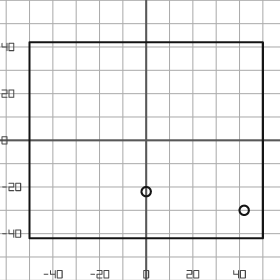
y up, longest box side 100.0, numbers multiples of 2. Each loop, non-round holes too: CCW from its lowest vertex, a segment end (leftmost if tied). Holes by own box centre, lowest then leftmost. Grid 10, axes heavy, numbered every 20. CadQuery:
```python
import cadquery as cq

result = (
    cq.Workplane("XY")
    .moveTo(-50.0, -42.0)
    .lineTo(50.0, -42.0)
    .lineTo(50.0, 42.0)
    .lineTo(-50.0, 42.0)
    .close()
    .moveTo(42.0, -30.0)
    .circle(2.0)
    .moveTo(0.0, -22.0)
    .circle(2.0)
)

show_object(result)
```